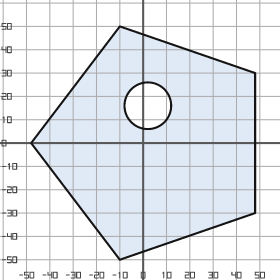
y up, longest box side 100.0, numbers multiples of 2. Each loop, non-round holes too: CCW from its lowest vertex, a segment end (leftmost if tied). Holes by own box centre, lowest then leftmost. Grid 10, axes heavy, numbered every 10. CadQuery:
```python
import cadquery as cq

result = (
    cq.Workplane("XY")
    .moveTo(-10.0, -50.0)
    .lineTo(48.0, -30.0)
    .lineTo(48.0, 30.0)
    .lineTo(-10.0, 50.0)
    .lineTo(-48.0, 0.0)
    .close()
    .moveTo(2.0, 16.0)
    .circle(10.0)
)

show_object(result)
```